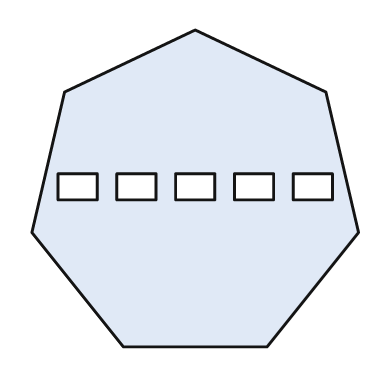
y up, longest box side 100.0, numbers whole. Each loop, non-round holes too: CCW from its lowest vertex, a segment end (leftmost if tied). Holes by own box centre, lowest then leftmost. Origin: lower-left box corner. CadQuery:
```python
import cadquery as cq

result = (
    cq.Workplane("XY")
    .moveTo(28.0, 0.0)
    .lineTo(72.0, 0.0)
    .lineTo(100.0, 35.0)
    .lineTo(90.0, 78.0)
    .lineTo(50.0, 97.0)
    .lineTo(10.0, 78.0)
    .lineTo(0.0, 35.0)
    .close()
    .moveTo(8.0, 45.0)
    .lineTo(20.0, 45.0)
    .lineTo(20.0, 53.0)
    .lineTo(8.0, 53.0)
    .close()
    .moveTo(26.0, 45.0)
    .lineTo(38.0, 45.0)
    .lineTo(38.0, 53.0)
    .lineTo(26.0, 53.0)
    .close()
    .moveTo(44.0, 45.0)
    .lineTo(56.0, 45.0)
    .lineTo(56.0, 53.0)
    .lineTo(44.0, 53.0)
    .close()
    .moveTo(62.0, 45.0)
    .lineTo(74.0, 45.0)
    .lineTo(74.0, 53.0)
    .lineTo(62.0, 53.0)
    .close()
    .moveTo(80.0, 45.0)
    .lineTo(92.0, 45.0)
    .lineTo(92.0, 53.0)
    .lineTo(80.0, 53.0)
    .close()
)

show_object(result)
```